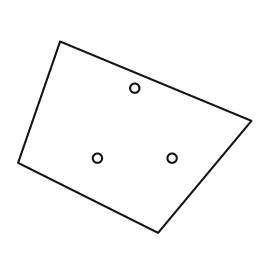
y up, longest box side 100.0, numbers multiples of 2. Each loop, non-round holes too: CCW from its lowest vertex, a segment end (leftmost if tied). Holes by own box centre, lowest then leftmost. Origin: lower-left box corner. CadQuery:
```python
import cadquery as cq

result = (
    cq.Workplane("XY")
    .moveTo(60.0, 0.0)
    .lineTo(100.0, 48.0)
    .lineTo(18.0, 82.0)
    .lineTo(0.0, 30.0)
    .close()
    .moveTo(34.0, 32.0)
    .circle(2.0)
    .moveTo(66.0, 32.0)
    .circle(2.0)
    .moveTo(50.0, 62.0)
    .circle(2.0)
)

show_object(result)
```